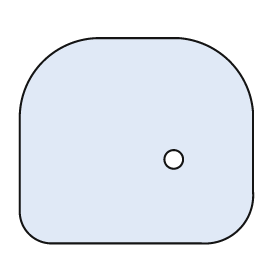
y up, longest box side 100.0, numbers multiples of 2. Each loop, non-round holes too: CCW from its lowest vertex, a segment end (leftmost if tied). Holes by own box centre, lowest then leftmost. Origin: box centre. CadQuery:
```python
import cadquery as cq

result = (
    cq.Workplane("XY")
    .moveTo(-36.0, -44.0)
    .lineTo(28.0, -44.0)
    .threePointArc((44.0, -38.0), (50.0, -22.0))
    .lineTo(50.0, 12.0)
    .threePointArc((40.0, 34.0), (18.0, 44.0))
    .lineTo(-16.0, 44.0)
    .threePointArc((-40.0, 34.0), (-50.0, 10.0))
    .lineTo(-50.0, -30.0)
    .threePointArc((-46.0, -40.0), (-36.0, -44.0))
    .close()
    .moveTo(16.0, -8.0)
    .circle(4.0)
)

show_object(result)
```